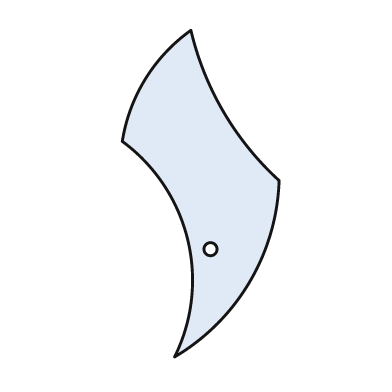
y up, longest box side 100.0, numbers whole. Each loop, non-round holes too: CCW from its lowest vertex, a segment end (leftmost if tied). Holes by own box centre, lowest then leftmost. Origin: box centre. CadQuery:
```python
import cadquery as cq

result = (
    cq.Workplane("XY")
    .moveTo(-8.0, -50.0)
    .threePointArc((15.0, -27.0), (24.0, 4.0))
    .threePointArc((7.0, 25.0), (-3.0, 50.0))
    .threePointArc((-17.0, 35.0), (-24.0, 16.0))
    .threePointArc((-4.0, -14.0), (-8.0, -50.0))
    .close()
    .moveTo(3.0, -17.0)
    .circle(2.0)
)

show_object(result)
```